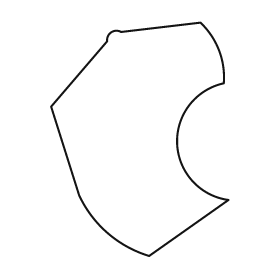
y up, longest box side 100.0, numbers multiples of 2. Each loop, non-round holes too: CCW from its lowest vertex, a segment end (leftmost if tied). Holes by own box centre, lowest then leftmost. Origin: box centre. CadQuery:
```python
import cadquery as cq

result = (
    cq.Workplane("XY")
    .moveTo(4.0, -50.0)
    .lineTo(38.0, -26.0)
    .threePointArc((16.0, -2.0), (36.0, 24.0))
    .threePointArc((34.0, 38.0), (26.0, 50.0))
    .lineTo(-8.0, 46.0)
    .threePointArc((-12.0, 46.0), (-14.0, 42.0))
    .lineTo(-38.0, 14.0)
    .lineTo(-26.0, -24.0)
    .threePointArc((-14.0, -40.0), (4.0, -50.0))
    .close()
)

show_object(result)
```